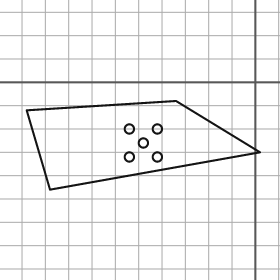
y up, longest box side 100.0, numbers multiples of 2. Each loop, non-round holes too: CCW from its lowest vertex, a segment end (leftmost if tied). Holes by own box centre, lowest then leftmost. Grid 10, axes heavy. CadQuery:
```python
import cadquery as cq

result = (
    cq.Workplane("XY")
    .moveTo(-88.0, -46.0)
    .lineTo(2.0, -30.0)
    .lineTo(-34.0, -8.0)
    .lineTo(-98.0, -12.0)
    .close()
    .moveTo(-54.0, -32.0)
    .circle(2.0)
    .moveTo(-42.0, -32.0)
    .circle(2.0)
    .moveTo(-48.0, -26.0)
    .circle(2.0)
    .moveTo(-54.0, -20.0)
    .circle(2.0)
    .moveTo(-42.0, -20.0)
    .circle(2.0)
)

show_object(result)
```